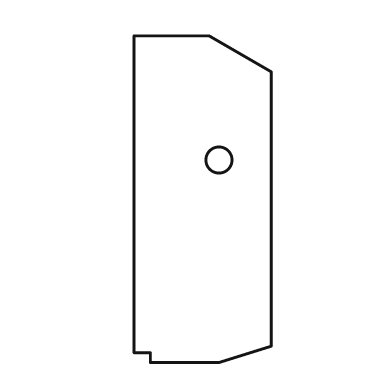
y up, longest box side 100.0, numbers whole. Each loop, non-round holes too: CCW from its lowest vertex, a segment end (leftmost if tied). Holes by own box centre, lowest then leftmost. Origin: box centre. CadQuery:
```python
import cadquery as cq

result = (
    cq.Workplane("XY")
    .moveTo(-16.0, -50.0)
    .lineTo(5.0, -50.0)
    .lineTo(21.0, -45.0)
    .lineTo(21.0, 39.0)
    .lineTo(2.0, 50.0)
    .lineTo(-21.0, 50.0)
    .lineTo(-21.0, -47.0)
    .lineTo(-16.0, -47.0)
    .close()
    .moveTo(5.0, 12.0)
    .circle(4.0)
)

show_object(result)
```